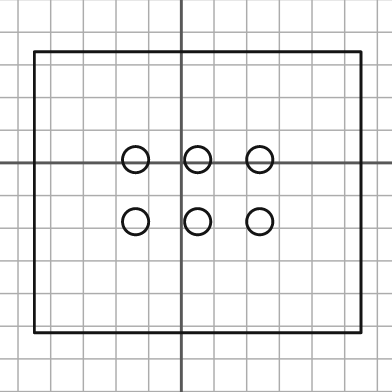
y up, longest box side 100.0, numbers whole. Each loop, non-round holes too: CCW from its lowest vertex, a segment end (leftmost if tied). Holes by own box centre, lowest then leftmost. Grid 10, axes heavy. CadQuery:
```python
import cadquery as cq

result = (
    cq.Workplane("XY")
    .moveTo(-45.0, -52.0)
    .lineTo(55.0, -52.0)
    .lineTo(55.0, 34.0)
    .lineTo(-45.0, 34.0)
    .close()
    .moveTo(-14.0, -18.0)
    .circle(4.0)
    .moveTo(5.0, -18.0)
    .circle(4.0)
    .moveTo(24.0, -18.0)
    .circle(4.0)
    .moveTo(-14.0, 1.0)
    .circle(4.0)
    .moveTo(5.0, 1.0)
    .circle(4.0)
    .moveTo(24.0, 1.0)
    .circle(4.0)
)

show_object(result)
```